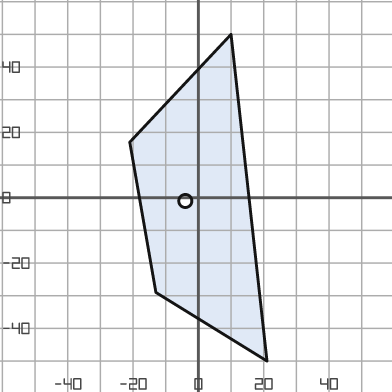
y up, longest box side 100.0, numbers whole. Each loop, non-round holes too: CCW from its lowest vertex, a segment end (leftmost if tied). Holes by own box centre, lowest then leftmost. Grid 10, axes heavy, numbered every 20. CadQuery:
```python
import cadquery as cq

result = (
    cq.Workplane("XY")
    .moveTo(21.0, -50.0)
    .lineTo(10.0, 50.0)
    .lineTo(-21.0, 17.0)
    .lineTo(-13.0, -29.0)
    .close()
    .moveTo(-4.0, -1.0)
    .circle(2.0)
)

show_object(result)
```